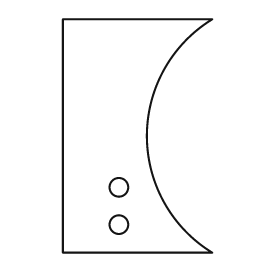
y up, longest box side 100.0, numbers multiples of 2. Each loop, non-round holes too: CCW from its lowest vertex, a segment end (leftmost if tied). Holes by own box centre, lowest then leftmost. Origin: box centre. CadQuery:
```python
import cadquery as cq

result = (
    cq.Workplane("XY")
    .moveTo(-32.0, -50.0)
    .lineTo(32.0, -50.0)
    .threePointArc((4.0, 0.0), (32.0, 50.0))
    .lineTo(-32.0, 50.0)
    .close()
    .moveTo(-8.0, -38.0)
    .circle(4.0)
    .moveTo(-8.0, -22.0)
    .circle(4.0)
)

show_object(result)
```